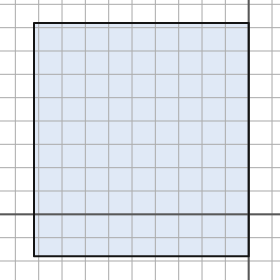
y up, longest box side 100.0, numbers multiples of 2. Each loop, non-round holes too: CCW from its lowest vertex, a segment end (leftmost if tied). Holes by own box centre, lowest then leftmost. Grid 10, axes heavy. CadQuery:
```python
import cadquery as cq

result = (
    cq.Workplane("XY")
    .moveTo(-92.0, -18.0)
    .lineTo(0.0, -18.0)
    .lineTo(0.0, 82.0)
    .lineTo(-92.0, 82.0)
    .close()
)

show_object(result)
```